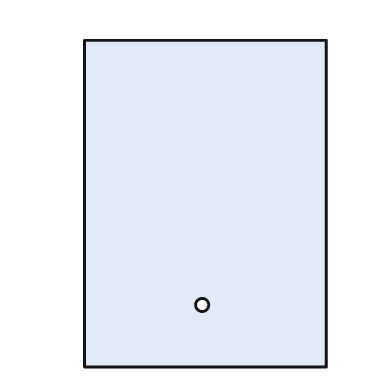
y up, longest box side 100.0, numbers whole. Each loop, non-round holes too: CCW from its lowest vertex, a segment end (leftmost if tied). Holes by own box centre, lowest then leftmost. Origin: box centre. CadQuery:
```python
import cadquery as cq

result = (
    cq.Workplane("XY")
    .moveTo(-37.0, -50.0)
    .lineTo(37.0, -50.0)
    .lineTo(37.0, 50.0)
    .lineTo(-37.0, 50.0)
    .close()
    .moveTo(-1.0, -31.0)
    .circle(2.0)
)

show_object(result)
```